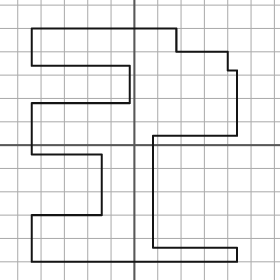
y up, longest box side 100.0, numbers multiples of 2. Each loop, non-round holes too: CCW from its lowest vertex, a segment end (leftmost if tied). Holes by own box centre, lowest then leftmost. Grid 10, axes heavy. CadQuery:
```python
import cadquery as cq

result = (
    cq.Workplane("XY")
    .moveTo(-44.0, -50.0)
    .lineTo(44.0, -50.0)
    .lineTo(44.0, -44.0)
    .lineTo(8.0, -44.0)
    .lineTo(8.0, 4.0)
    .lineTo(44.0, 4.0)
    .lineTo(44.0, 32.0)
    .lineTo(40.0, 32.0)
    .lineTo(40.0, 40.0)
    .lineTo(18.0, 40.0)
    .lineTo(18.0, 50.0)
    .lineTo(-44.0, 50.0)
    .lineTo(-44.0, 34.0)
    .lineTo(-2.0, 34.0)
    .lineTo(-2.0, 18.0)
    .lineTo(-44.0, 18.0)
    .lineTo(-44.0, -4.0)
    .lineTo(-14.0, -4.0)
    .lineTo(-14.0, -30.0)
    .lineTo(-44.0, -30.0)
    .close()
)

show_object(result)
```